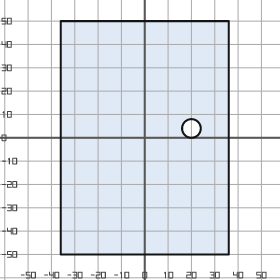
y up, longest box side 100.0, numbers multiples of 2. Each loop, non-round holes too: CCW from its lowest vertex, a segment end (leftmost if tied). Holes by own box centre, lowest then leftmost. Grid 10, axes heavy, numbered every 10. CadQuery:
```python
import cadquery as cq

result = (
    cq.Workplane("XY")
    .moveTo(-36.0, -50.0)
    .lineTo(36.0, -50.0)
    .lineTo(36.0, 50.0)
    .lineTo(-36.0, 50.0)
    .close()
    .moveTo(20.0, 4.0)
    .circle(4.0)
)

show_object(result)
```